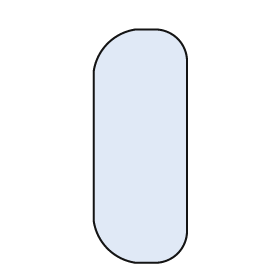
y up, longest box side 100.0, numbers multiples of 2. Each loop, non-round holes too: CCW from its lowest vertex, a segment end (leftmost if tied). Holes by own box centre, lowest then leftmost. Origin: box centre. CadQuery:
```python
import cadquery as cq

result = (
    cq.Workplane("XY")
    .moveTo(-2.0, -50.0)
    .lineTo(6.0, -50.0)
    .threePointArc((16.0, -46.0), (20.0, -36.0))
    .lineTo(20.0, 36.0)
    .threePointArc((16.0, 46.0), (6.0, 50.0))
    .lineTo(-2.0, 50.0)
    .threePointArc((-14.0, 44.0), (-20.0, 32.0))
    .lineTo(-20.0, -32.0)
    .threePointArc((-14.0, -44.0), (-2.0, -50.0))
    .close()
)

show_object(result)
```